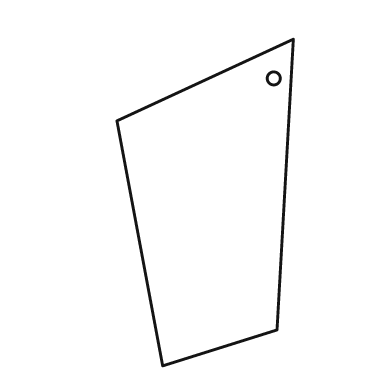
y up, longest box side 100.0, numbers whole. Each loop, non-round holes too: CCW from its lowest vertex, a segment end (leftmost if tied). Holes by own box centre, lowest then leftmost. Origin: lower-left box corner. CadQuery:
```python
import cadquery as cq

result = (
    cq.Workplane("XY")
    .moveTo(14.0, 0.0)
    .lineTo(49.0, 11.0)
    .lineTo(54.0, 100.0)
    .lineTo(0.0, 75.0)
    .close()
    .moveTo(48.0, 88.0)
    .circle(2.0)
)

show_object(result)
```